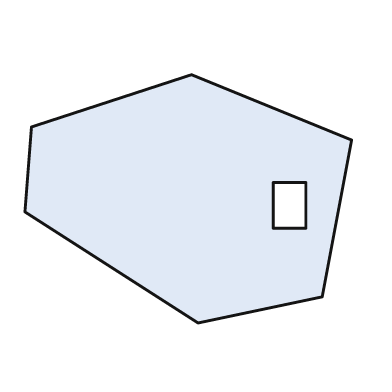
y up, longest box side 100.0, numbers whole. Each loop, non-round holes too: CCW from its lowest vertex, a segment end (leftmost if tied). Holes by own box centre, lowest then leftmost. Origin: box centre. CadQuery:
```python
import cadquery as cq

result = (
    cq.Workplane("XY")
    .moveTo(3.0, -38.0)
    .lineTo(41.0, -30.0)
    .lineTo(50.0, 18.0)
    .lineTo(1.0, 38.0)
    .lineTo(-48.0, 22.0)
    .lineTo(-50.0, -4.0)
    .close()
    .moveTo(26.0, -9.0)
    .lineTo(36.0, -9.0)
    .lineTo(36.0, 5.0)
    .lineTo(26.0, 5.0)
    .close()
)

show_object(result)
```